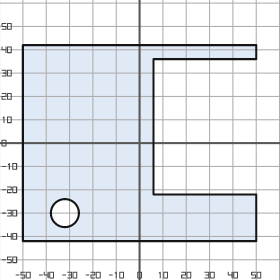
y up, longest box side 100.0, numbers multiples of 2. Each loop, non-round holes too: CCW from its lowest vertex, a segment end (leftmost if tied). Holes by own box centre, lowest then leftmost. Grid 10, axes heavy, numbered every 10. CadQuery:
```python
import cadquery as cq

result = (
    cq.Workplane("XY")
    .moveTo(-50.0, -42.0)
    .lineTo(50.0, -42.0)
    .lineTo(50.0, -22.0)
    .lineTo(6.0, -22.0)
    .lineTo(6.0, 36.0)
    .lineTo(50.0, 36.0)
    .lineTo(50.0, 42.0)
    .lineTo(-50.0, 42.0)
    .close()
    .moveTo(-32.0, -30.0)
    .circle(6.0)
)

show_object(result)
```